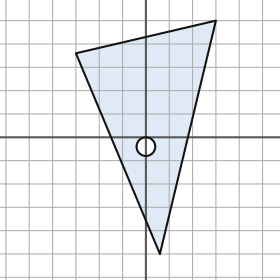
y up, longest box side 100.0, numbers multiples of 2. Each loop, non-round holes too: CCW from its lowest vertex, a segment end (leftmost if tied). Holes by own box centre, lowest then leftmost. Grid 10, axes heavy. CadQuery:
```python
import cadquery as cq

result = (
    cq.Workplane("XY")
    .moveTo(6.0, -50.0)
    .lineTo(30.0, 50.0)
    .lineTo(-30.0, 36.0)
    .close()
    .moveTo(0.0, -4.0)
    .circle(4.0)
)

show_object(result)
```